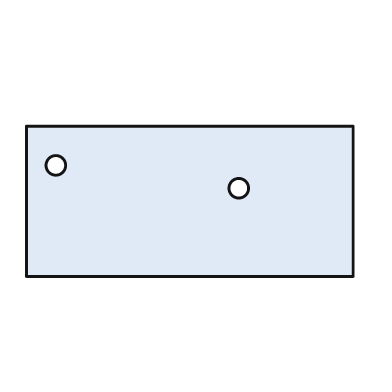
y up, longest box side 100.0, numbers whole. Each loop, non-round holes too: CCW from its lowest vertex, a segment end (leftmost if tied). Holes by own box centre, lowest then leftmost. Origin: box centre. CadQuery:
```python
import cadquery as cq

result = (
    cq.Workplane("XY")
    .moveTo(-50.0, -23.0)
    .lineTo(50.0, -23.0)
    .lineTo(50.0, 23.0)
    .lineTo(-50.0, 23.0)
    .close()
    .moveTo(15.0, 4.0)
    .circle(3.0)
    .moveTo(-41.0, 11.0)
    .circle(3.0)
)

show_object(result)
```